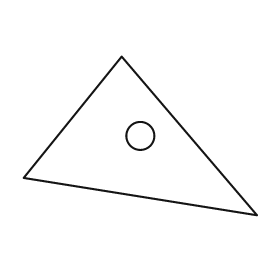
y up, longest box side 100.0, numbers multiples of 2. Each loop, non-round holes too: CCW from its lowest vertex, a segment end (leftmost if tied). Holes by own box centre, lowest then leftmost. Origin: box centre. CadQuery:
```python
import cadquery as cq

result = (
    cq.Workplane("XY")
    .moveTo(50.0, -34.0)
    .lineTo(-8.0, 34.0)
    .lineTo(-50.0, -18.0)
    .close()
    .moveTo(0.0, 0.0)
    .circle(6.0)
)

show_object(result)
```